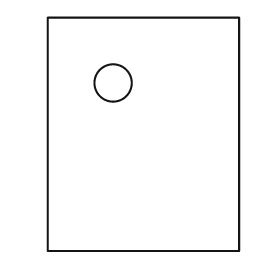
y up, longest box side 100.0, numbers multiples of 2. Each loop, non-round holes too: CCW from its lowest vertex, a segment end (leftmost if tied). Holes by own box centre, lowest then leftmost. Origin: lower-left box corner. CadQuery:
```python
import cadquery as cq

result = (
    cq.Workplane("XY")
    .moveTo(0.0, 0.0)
    .lineTo(82.0, 0.0)
    .lineTo(82.0, 100.0)
    .lineTo(0.0, 100.0)
    .close()
    .moveTo(28.0, 72.0)
    .circle(8.0)
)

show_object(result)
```